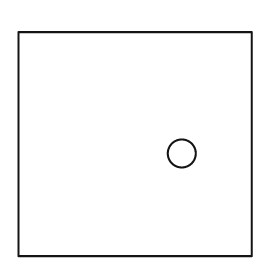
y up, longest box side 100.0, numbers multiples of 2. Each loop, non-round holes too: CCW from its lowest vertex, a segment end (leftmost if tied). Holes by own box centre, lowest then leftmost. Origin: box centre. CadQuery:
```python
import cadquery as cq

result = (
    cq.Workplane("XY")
    .moveTo(-50.0, -48.0)
    .lineTo(50.0, -48.0)
    .lineTo(50.0, 48.0)
    .lineTo(-50.0, 48.0)
    .close()
    .moveTo(20.0, -4.0)
    .circle(6.0)
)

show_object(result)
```